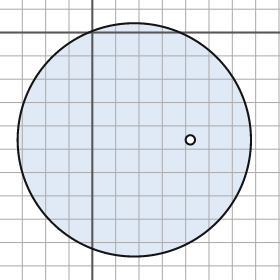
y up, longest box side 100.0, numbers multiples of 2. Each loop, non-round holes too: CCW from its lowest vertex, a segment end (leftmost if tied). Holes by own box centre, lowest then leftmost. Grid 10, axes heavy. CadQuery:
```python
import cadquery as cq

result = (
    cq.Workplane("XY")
    .moveTo(18.0, -46.0)
    .circle(50.0)
    .moveTo(42.0, -46.0)
    .circle(2.0)
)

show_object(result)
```